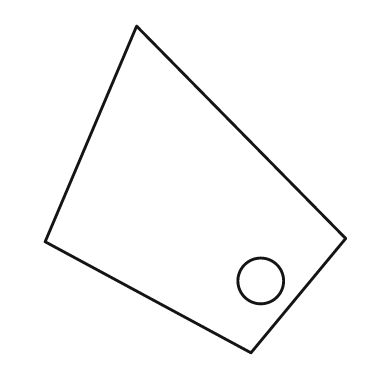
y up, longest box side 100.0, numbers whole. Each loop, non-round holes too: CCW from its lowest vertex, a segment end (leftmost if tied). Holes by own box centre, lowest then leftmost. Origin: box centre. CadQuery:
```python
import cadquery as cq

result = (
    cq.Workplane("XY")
    .moveTo(17.0, -50.0)
    .lineTo(46.0, -15.0)
    .lineTo(-18.0, 50.0)
    .lineTo(-46.0, -16.0)
    .close()
    .moveTo(20.0, -28.0)
    .circle(7.0)
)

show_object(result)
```